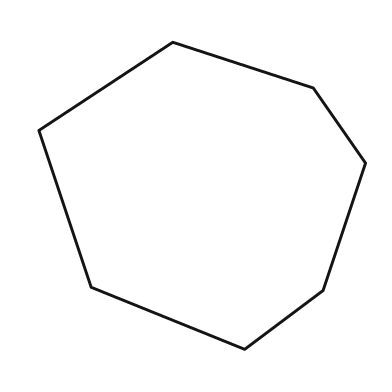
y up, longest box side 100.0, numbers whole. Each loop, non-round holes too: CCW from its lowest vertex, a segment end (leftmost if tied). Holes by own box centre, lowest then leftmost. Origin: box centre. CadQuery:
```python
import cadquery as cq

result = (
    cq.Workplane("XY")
    .moveTo(13.0, -47.0)
    .lineTo(37.0, -29.0)
    .lineTo(50.0, 10.0)
    .lineTo(34.0, 33.0)
    .lineTo(-9.0, 47.0)
    .lineTo(-50.0, 20.0)
    .lineTo(-34.0, -28.0)
    .close()
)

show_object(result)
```